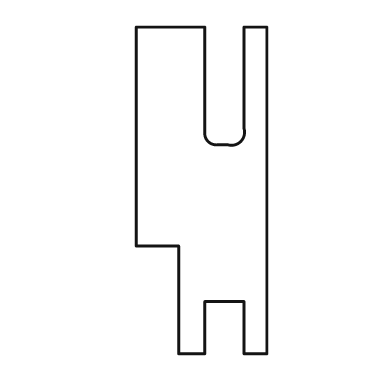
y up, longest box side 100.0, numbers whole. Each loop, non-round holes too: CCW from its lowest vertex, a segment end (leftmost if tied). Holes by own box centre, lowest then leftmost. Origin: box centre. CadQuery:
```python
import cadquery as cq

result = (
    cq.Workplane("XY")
    .moveTo(-7.0, -50.0)
    .lineTo(1.0, -50.0)
    .lineTo(1.0, -34.0)
    .lineTo(13.0, -34.0)
    .lineTo(13.0, -50.0)
    .lineTo(20.0, -50.0)
    .lineTo(20.0, 50.0)
    .lineTo(13.0, 50.0)
    .lineTo(13.0, 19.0)
    .threePointArc((12.0, 15.0), (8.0, 14.0))
    .lineTo(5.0, 14.0)
    .threePointArc((2.0, 15.0), (1.0, 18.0))
    .lineTo(1.0, 50.0)
    .lineTo(-20.0, 50.0)
    .lineTo(-20.0, -17.0)
    .lineTo(-7.0, -17.0)
    .close()
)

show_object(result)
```